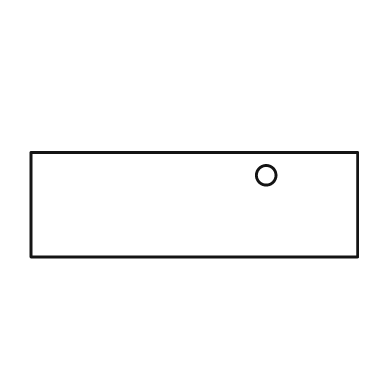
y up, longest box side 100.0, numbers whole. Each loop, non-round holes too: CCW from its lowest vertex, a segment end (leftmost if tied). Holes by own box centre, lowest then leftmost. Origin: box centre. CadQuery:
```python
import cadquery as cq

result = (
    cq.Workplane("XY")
    .moveTo(-50.0, -16.0)
    .lineTo(50.0, -16.0)
    .lineTo(50.0, 16.0)
    .lineTo(-50.0, 16.0)
    .close()
    .moveTo(22.0, 9.0)
    .circle(3.0)
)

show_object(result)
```